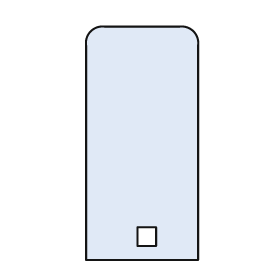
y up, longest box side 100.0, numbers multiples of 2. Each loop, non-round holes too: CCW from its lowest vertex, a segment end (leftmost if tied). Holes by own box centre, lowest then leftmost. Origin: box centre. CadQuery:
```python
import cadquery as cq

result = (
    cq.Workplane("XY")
    .moveTo(-24.0, -50.0)
    .lineTo(24.0, -50.0)
    .lineTo(24.0, 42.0)
    .threePointArc((22.0, 48.0), (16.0, 50.0))
    .lineTo(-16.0, 50.0)
    .threePointArc((-22.0, 48.0), (-24.0, 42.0))
    .close()
    .moveTo(-2.0, -44.0)
    .lineTo(6.0, -44.0)
    .lineTo(6.0, -36.0)
    .lineTo(-2.0, -36.0)
    .close()
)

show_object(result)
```